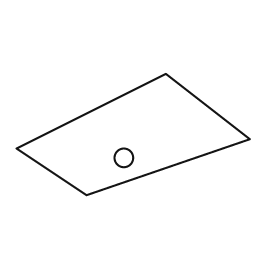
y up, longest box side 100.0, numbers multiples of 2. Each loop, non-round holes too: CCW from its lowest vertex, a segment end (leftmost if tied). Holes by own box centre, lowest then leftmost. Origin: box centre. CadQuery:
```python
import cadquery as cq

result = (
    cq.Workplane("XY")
    .moveTo(-20.0, -26.0)
    .lineTo(50.0, -2.0)
    .lineTo(14.0, 26.0)
    .lineTo(-50.0, -6.0)
    .close()
    .moveTo(-4.0, -10.0)
    .circle(4.0)
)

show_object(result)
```